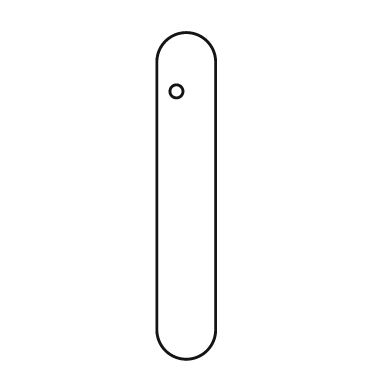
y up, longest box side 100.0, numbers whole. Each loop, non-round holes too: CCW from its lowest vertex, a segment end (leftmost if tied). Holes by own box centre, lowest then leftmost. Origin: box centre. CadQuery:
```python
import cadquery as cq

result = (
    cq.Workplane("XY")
    .moveTo(-9.0, -41.0)
    .threePointArc((0.0, -50.0), (9.0, -41.0))
    .lineTo(9.0, 41.0)
    .threePointArc((0.0, 50.0), (-9.0, 41.0))
    .close()
    .moveTo(-3.0, 32.0)
    .circle(2.0)
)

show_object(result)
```